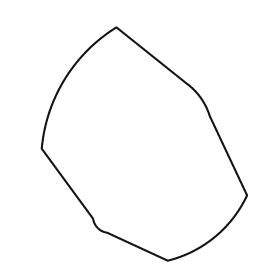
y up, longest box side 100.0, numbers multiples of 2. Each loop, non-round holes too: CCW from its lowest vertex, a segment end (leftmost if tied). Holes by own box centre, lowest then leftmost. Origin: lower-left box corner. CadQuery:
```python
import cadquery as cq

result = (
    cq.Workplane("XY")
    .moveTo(54.0, 0.0)
    .threePointArc((74.0, 10.0), (88.0, 28.0))
    .lineTo(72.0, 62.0)
    .threePointArc((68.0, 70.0), (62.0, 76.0))
    .lineTo(32.0, 100.0)
    .threePointArc((10.0, 78.0), (0.0, 48.0))
    .lineTo(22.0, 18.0)
    .threePointArc((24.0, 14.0), (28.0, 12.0))
    .close()
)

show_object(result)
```